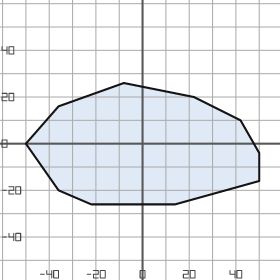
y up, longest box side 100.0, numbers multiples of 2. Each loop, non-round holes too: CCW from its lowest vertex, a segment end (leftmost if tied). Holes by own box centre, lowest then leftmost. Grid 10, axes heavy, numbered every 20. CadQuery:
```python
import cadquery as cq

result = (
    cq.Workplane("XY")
    .moveTo(-22.0, -26.0)
    .lineTo(14.0, -26.0)
    .lineTo(50.0, -16.0)
    .lineTo(50.0, -4.0)
    .lineTo(42.0, 10.0)
    .lineTo(22.0, 20.0)
    .lineTo(-8.0, 26.0)
    .lineTo(-36.0, 16.0)
    .lineTo(-50.0, 0.0)
    .lineTo(-36.0, -20.0)
    .close()
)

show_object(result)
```